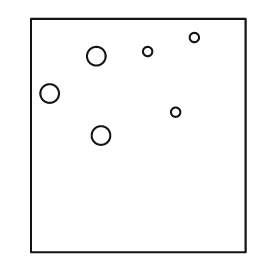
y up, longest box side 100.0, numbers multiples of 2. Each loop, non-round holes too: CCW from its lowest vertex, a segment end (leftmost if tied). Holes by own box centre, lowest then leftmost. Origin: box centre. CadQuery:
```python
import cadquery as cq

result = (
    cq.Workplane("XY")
    .moveTo(-46.0, -50.0)
    .lineTo(46.0, -50.0)
    .lineTo(46.0, 50.0)
    .lineTo(-46.0, 50.0)
    .close()
    .moveTo(-16.0, 0.0)
    .circle(4.0)
    .moveTo(16.0, 10.0)
    .circle(2.0)
    .moveTo(-38.0, 18.0)
    .circle(4.0)
    .moveTo(-18.0, 34.0)
    .circle(4.0)
    .moveTo(4.0, 36.0)
    .circle(2.0)
    .moveTo(24.0, 42.0)
    .circle(2.0)
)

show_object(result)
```